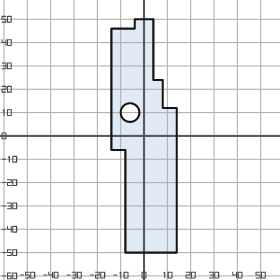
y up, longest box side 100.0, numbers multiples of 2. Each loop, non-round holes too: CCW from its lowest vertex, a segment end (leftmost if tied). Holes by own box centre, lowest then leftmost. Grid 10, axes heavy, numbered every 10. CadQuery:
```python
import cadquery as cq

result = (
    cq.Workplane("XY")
    .moveTo(-8.0, -50.0)
    .lineTo(14.0, -50.0)
    .lineTo(14.0, 12.0)
    .lineTo(8.0, 12.0)
    .lineTo(8.0, 24.0)
    .lineTo(4.0, 24.0)
    .lineTo(4.0, 50.0)
    .lineTo(-4.0, 50.0)
    .lineTo(-4.0, 46.0)
    .lineTo(-14.0, 46.0)
    .lineTo(-14.0, -6.0)
    .lineTo(-8.0, -6.0)
    .close()
    .moveTo(-6.0, 10.0)
    .circle(4.0)
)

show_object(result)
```